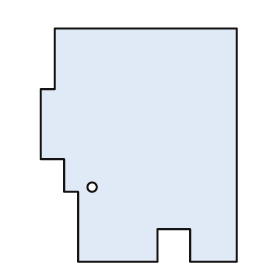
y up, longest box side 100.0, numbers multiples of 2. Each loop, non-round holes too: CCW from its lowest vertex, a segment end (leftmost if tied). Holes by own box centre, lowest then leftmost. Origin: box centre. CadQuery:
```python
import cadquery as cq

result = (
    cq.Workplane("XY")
    .moveTo(-26.0, -50.0)
    .lineTo(8.0, -50.0)
    .lineTo(8.0, -36.0)
    .lineTo(22.0, -36.0)
    .lineTo(22.0, -50.0)
    .lineTo(42.0, -50.0)
    .lineTo(42.0, 50.0)
    .lineTo(-36.0, 50.0)
    .lineTo(-36.0, 24.0)
    .lineTo(-42.0, 24.0)
    .lineTo(-42.0, -6.0)
    .lineTo(-32.0, -6.0)
    .lineTo(-32.0, -20.0)
    .lineTo(-26.0, -20.0)
    .close()
    .moveTo(-20.0, -18.0)
    .circle(2.0)
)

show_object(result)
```